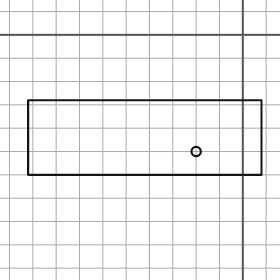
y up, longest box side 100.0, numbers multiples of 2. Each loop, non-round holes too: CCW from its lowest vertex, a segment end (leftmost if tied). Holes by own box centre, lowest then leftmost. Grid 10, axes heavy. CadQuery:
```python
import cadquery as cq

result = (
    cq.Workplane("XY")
    .moveTo(-92.0, -60.0)
    .lineTo(8.0, -60.0)
    .lineTo(8.0, -28.0)
    .lineTo(-92.0, -28.0)
    .close()
    .moveTo(-20.0, -50.0)
    .circle(2.0)
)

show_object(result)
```